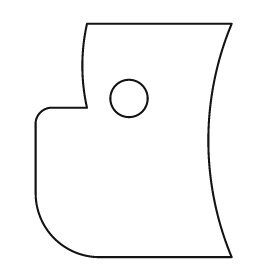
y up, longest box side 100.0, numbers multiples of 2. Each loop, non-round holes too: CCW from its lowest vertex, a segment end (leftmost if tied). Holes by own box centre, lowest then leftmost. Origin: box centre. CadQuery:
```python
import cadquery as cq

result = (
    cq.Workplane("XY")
    .moveTo(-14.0, -50.0)
    .lineTo(42.0, -50.0)
    .threePointArc((32.0, 0.0), (42.0, 50.0))
    .lineTo(-20.0, 50.0)
    .threePointArc((-22.0, 32.0), (-20.0, 14.0))
    .lineTo(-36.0, 14.0)
    .threePointArc((-40.0, 12.0), (-42.0, 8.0))
    .lineTo(-42.0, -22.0)
    .threePointArc((-34.0, -42.0), (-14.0, -50.0))
    .close()
    .moveTo(-2.0, 18.0)
    .circle(8.0)
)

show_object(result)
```